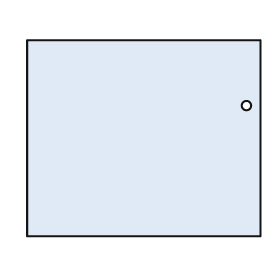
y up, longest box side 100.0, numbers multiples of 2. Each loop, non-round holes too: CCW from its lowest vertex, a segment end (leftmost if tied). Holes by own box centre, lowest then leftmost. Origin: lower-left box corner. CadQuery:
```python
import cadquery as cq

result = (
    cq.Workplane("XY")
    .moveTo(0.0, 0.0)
    .lineTo(100.0, 0.0)
    .lineTo(100.0, 84.0)
    .lineTo(0.0, 84.0)
    .close()
    .moveTo(94.0, 56.0)
    .circle(2.0)
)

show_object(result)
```